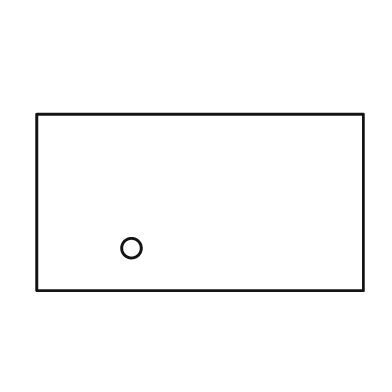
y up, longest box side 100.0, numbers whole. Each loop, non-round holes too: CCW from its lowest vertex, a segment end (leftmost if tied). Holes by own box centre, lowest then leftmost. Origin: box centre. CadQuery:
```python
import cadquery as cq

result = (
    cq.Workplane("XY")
    .moveTo(-50.0, -27.0)
    .lineTo(50.0, -27.0)
    .lineTo(50.0, 27.0)
    .lineTo(-50.0, 27.0)
    .close()
    .moveTo(-21.0, -14.0)
    .circle(3.0)
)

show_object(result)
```